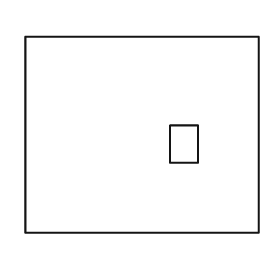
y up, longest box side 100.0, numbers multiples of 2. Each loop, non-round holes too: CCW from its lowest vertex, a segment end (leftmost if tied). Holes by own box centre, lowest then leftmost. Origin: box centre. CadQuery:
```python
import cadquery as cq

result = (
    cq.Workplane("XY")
    .moveTo(-50.0, -42.0)
    .lineTo(50.0, -42.0)
    .lineTo(50.0, 42.0)
    .lineTo(-50.0, 42.0)
    .close()
    .moveTo(12.0, -12.0)
    .lineTo(24.0, -12.0)
    .lineTo(24.0, 4.0)
    .lineTo(12.0, 4.0)
    .close()
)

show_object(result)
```